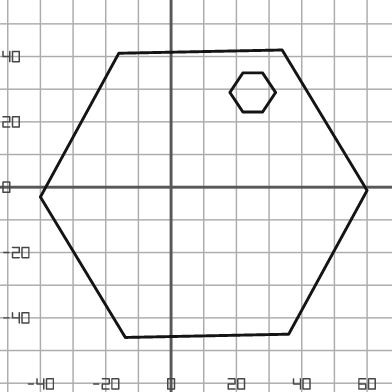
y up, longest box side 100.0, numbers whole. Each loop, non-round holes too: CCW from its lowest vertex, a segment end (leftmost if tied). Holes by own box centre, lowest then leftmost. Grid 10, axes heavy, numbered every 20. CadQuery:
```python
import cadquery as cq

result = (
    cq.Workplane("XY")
    .moveTo(-14.0, -46.0)
    .lineTo(36.0, -45.0)
    .lineTo(60.0, -1.0)
    .lineTo(34.0, 42.0)
    .lineTo(-16.0, 41.0)
    .lineTo(-40.0, -3.0)
    .close()
    .moveTo(22.0, 23.0)
    .lineTo(28.0, 23.0)
    .lineTo(32.0, 29.0)
    .lineTo(28.0, 35.0)
    .lineTo(22.0, 35.0)
    .lineTo(18.0, 29.0)
    .close()
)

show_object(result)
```